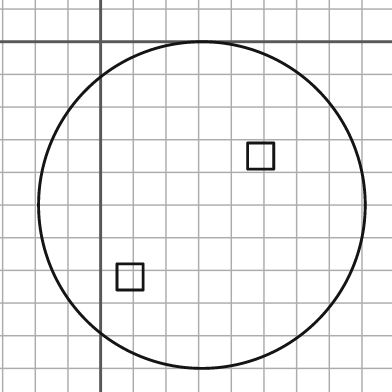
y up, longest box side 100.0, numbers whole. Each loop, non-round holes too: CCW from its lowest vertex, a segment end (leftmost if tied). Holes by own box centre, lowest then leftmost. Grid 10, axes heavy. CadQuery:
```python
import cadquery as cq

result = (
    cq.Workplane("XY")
    .moveTo(31.0, -50.0)
    .circle(50.0)
    .moveTo(5.0, -76.0)
    .lineTo(13.0, -76.0)
    .lineTo(13.0, -68.0)
    .lineTo(5.0, -68.0)
    .close()
    .moveTo(45.0, -39.0)
    .lineTo(53.0, -39.0)
    .lineTo(53.0, -31.0)
    .lineTo(45.0, -31.0)
    .close()
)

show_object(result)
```